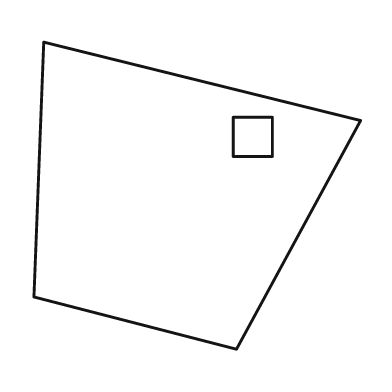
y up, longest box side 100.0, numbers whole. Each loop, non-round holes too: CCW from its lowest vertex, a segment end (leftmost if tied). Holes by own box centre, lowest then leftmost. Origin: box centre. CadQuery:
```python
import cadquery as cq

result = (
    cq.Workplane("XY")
    .moveTo(12.0, -47.0)
    .lineTo(50.0, 23.0)
    .lineTo(-47.0, 47.0)
    .lineTo(-50.0, -31.0)
    .close()
    .moveTo(11.0, 12.0)
    .lineTo(23.0, 12.0)
    .lineTo(23.0, 24.0)
    .lineTo(11.0, 24.0)
    .close()
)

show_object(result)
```